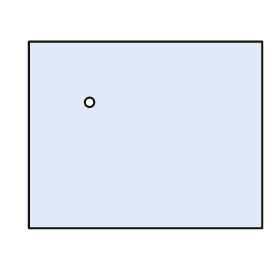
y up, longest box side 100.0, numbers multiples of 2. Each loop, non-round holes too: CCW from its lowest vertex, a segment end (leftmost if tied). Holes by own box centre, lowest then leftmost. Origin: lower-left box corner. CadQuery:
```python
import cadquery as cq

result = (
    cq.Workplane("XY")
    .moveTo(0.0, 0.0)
    .lineTo(100.0, 0.0)
    .lineTo(100.0, 80.0)
    .lineTo(0.0, 80.0)
    .close()
    .moveTo(26.0, 54.0)
    .circle(2.0)
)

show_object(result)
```